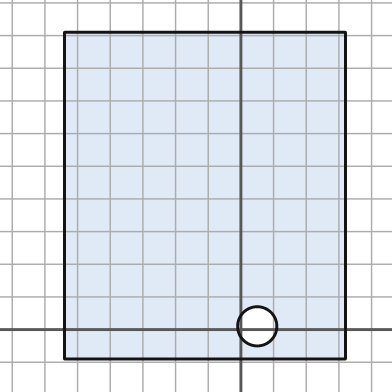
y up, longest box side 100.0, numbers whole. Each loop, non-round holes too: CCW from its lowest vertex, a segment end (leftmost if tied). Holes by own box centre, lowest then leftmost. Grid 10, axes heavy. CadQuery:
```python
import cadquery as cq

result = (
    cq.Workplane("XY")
    .moveTo(-54.0, -9.0)
    .lineTo(32.0, -9.0)
    .lineTo(32.0, 91.0)
    .lineTo(-54.0, 91.0)
    .close()
    .moveTo(5.0, 1.0)
    .circle(6.0)
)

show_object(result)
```